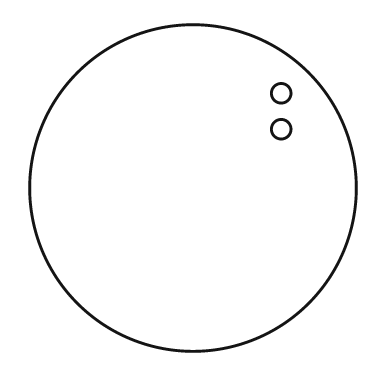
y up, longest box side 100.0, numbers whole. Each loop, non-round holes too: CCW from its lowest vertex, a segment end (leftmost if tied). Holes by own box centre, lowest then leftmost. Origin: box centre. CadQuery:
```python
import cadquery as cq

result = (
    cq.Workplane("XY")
    .moveTo(0.0, 0.0)
    .circle(50.0)
    .moveTo(27.0, 18.0)
    .circle(3.0)
    .moveTo(27.0, 29.0)
    .circle(3.0)
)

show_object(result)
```